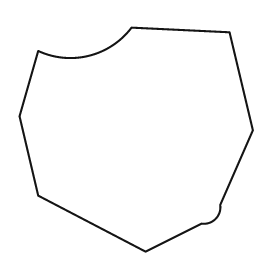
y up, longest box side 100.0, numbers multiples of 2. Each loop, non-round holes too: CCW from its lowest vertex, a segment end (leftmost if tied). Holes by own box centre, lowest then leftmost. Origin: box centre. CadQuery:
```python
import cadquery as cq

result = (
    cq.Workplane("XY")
    .moveTo(4.0, -48.0)
    .lineTo(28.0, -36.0)
    .threePointArc((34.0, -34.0), (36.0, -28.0))
    .lineTo(50.0, 4.0)
    .lineTo(40.0, 46.0)
    .lineTo(-2.0, 48.0)
    .threePointArc((-20.0, 36.0), (-42.0, 38.0))
    .lineTo(-50.0, 10.0)
    .lineTo(-42.0, -24.0)
    .close()
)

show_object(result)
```